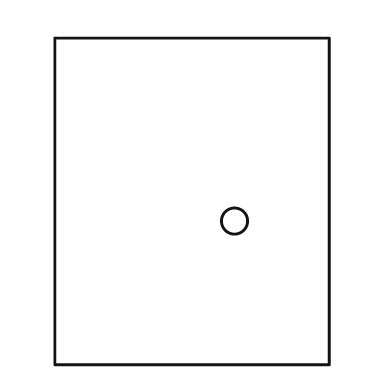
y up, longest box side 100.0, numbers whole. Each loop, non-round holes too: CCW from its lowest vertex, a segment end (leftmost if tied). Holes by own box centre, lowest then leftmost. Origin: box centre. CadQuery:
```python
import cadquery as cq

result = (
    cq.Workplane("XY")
    .moveTo(-42.0, -50.0)
    .lineTo(42.0, -50.0)
    .lineTo(42.0, 50.0)
    .lineTo(-42.0, 50.0)
    .close()
    .moveTo(13.0, -6.0)
    .circle(4.0)
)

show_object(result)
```